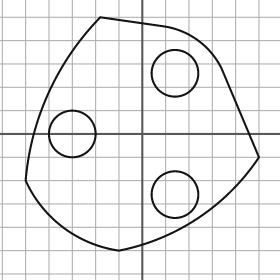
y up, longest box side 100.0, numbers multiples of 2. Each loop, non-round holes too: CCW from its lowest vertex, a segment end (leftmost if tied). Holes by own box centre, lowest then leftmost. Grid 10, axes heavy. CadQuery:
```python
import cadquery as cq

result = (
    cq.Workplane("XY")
    .moveTo(-10.0, -50.0)
    .threePointArc((24.0, -36.0), (50.0, -10.0))
    .lineTo(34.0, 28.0)
    .threePointArc((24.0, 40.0), (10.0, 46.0))
    .lineTo(-18.0, 50.0)
    .threePointArc((-40.0, 18.0), (-50.0, -20.0))
    .threePointArc((-34.0, -40.0), (-10.0, -50.0))
    .close()
    .moveTo(14.0, -26.0)
    .circle(10.0)
    .moveTo(-30.0, 0.0)
    .circle(10.0)
    .moveTo(14.0, 26.0)
    .circle(10.0)
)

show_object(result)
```